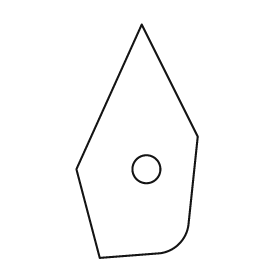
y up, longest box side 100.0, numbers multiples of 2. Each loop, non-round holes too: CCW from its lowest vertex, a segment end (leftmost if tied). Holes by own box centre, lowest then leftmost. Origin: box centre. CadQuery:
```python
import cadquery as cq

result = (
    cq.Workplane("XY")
    .moveTo(-16.0, -50.0)
    .lineTo(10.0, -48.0)
    .threePointArc((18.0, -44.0), (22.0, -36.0))
    .lineTo(26.0, 2.0)
    .lineTo(2.0, 50.0)
    .lineTo(-26.0, -12.0)
    .close()
    .moveTo(4.0, -12.0)
    .circle(6.0)
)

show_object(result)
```